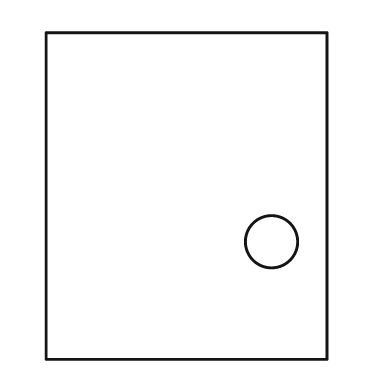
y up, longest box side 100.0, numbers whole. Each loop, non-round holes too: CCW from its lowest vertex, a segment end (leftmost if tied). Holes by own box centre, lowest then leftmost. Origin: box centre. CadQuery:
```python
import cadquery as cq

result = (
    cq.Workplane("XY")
    .moveTo(-43.0, -50.0)
    .lineTo(43.0, -50.0)
    .lineTo(43.0, 50.0)
    .lineTo(-43.0, 50.0)
    .close()
    .moveTo(26.0, -14.0)
    .circle(8.0)
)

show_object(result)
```